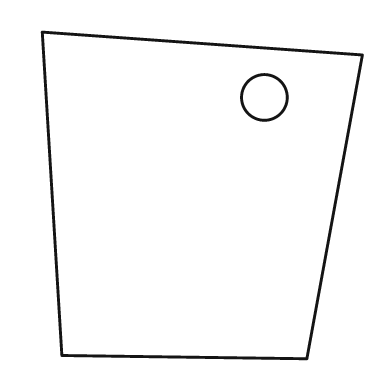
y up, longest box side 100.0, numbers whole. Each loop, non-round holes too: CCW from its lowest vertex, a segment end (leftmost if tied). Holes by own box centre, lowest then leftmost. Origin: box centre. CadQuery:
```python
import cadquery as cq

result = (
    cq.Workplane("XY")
    .moveTo(32.0, -50.0)
    .lineTo(49.0, 43.0)
    .lineTo(-49.0, 50.0)
    .lineTo(-43.0, -49.0)
    .close()
    .moveTo(19.0, 30.0)
    .circle(7.0)
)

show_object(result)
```